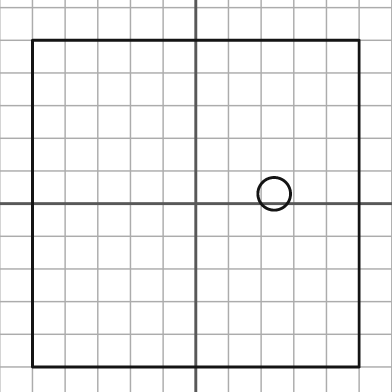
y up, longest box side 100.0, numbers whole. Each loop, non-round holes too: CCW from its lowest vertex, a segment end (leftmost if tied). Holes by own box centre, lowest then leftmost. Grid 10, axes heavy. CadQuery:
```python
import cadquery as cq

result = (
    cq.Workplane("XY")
    .moveTo(-50.0, -50.0)
    .lineTo(50.0, -50.0)
    .lineTo(50.0, 50.0)
    .lineTo(-50.0, 50.0)
    .close()
    .moveTo(24.0, 3.0)
    .circle(5.0)
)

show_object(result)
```